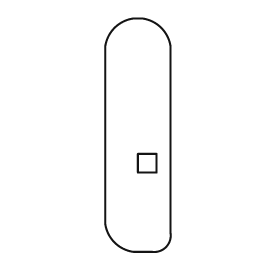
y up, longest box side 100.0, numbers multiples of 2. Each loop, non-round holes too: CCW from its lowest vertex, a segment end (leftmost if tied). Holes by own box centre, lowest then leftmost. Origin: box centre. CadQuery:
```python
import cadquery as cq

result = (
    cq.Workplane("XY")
    .moveTo(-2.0, -50.0)
    .lineTo(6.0, -50.0)
    .threePointArc((12.0, -48.0), (14.0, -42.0))
    .lineTo(14.0, 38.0)
    .threePointArc((10.0, 46.0), (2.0, 50.0))
    .lineTo(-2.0, 50.0)
    .threePointArc((-10.0, 46.0), (-14.0, 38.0))
    .lineTo(-14.0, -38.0)
    .threePointArc((-10.0, -46.0), (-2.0, -50.0))
    .close()
    .moveTo(0.0, -16.0)
    .lineTo(8.0, -16.0)
    .lineTo(8.0, -8.0)
    .lineTo(0.0, -8.0)
    .close()
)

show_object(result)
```